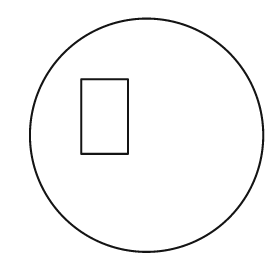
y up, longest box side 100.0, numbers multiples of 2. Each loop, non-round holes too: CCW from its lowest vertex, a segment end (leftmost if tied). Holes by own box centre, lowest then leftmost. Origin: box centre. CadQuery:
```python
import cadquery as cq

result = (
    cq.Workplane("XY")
    .moveTo(0.0, 0.0)
    .circle(50.0)
    .moveTo(-28.0, -8.0)
    .lineTo(-8.0, -8.0)
    .lineTo(-8.0, 24.0)
    .lineTo(-28.0, 24.0)
    .close()
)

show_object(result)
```